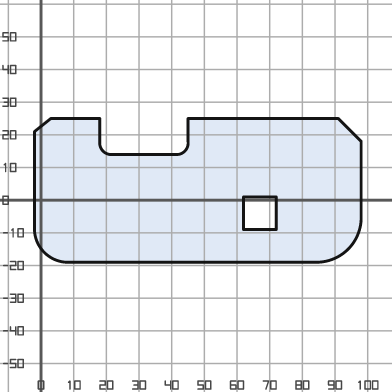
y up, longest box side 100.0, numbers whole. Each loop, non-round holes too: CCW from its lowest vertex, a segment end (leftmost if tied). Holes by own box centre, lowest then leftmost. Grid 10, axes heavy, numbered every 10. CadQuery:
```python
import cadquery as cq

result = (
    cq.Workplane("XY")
    .moveTo(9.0, -19.0)
    .lineTo(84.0, -19.0)
    .threePointArc((94.0, -15.0), (98.0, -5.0))
    .lineTo(98.0, 18.0)
    .lineTo(91.0, 25.0)
    .lineTo(45.0, 25.0)
    .lineTo(45.0, 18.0)
    .threePointArc((44.0, 15.0), (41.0, 14.0))
    .lineTo(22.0, 14.0)
    .threePointArc((19.0, 15.0), (18.0, 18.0))
    .lineTo(18.0, 25.0)
    .lineTo(3.0, 25.0)
    .lineTo(-2.0, 21.0)
    .lineTo(-2.0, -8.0)
    .threePointArc((1.0, -16.0), (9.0, -19.0))
    .close()
    .moveTo(62.0, -9.0)
    .lineTo(72.0, -9.0)
    .lineTo(72.0, 1.0)
    .lineTo(62.0, 1.0)
    .close()
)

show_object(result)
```